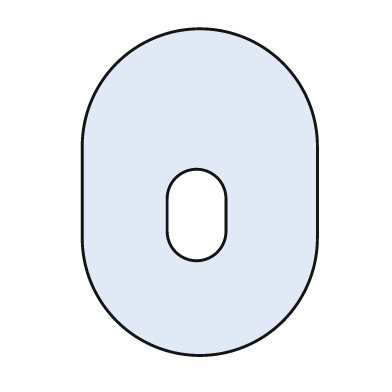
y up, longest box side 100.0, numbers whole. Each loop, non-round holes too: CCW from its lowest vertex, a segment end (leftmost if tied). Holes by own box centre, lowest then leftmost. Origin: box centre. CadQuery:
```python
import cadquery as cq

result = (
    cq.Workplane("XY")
    .moveTo(-36.0, -14.0)
    .threePointArc((0.0, -50.0), (36.0, -14.0))
    .lineTo(36.0, 14.0)
    .threePointArc((0.0, 50.0), (-36.0, 14.0))
    .close()
    .moveTo(-10.0, -12.0)
    .threePointArc((-1.0, -21.0), (8.0, -12.0))
    .lineTo(8.0, -2.0)
    .threePointArc((-1.0, 7.0), (-10.0, -2.0))
    .close()
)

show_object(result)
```